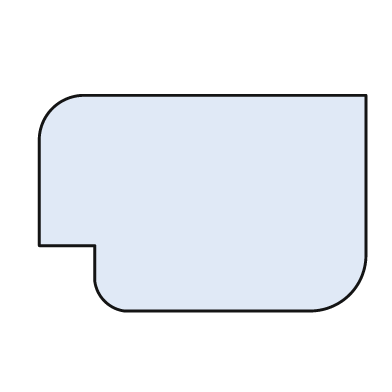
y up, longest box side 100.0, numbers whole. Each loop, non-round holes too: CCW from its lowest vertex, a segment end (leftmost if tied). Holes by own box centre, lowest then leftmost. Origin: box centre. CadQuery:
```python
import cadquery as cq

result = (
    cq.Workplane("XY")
    .moveTo(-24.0, -33.0)
    .lineTo(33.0, -33.0)
    .threePointArc((45.0, -28.0), (50.0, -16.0))
    .lineTo(50.0, 33.0)
    .lineTo(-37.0, 33.0)
    .threePointArc((-46.0, 29.0), (-50.0, 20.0))
    .lineTo(-50.0, -13.0)
    .lineTo(-33.0, -13.0)
    .lineTo(-33.0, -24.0)
    .threePointArc((-30.0, -30.0), (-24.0, -33.0))
    .close()
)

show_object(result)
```